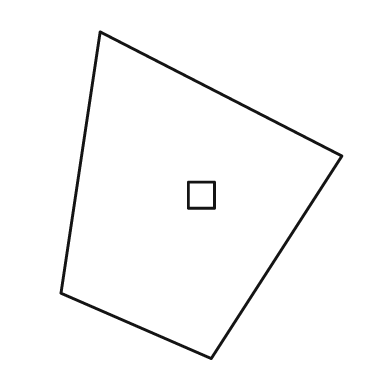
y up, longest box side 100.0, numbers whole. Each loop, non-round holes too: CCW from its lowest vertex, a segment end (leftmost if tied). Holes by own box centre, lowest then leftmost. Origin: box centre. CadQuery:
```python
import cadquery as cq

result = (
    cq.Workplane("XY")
    .moveTo(3.0, -50.0)
    .lineTo(43.0, 12.0)
    .lineTo(-31.0, 50.0)
    .lineTo(-43.0, -30.0)
    .close()
    .moveTo(-4.0, -4.0)
    .lineTo(4.0, -4.0)
    .lineTo(4.0, 4.0)
    .lineTo(-4.0, 4.0)
    .close()
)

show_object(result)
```